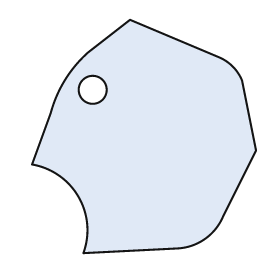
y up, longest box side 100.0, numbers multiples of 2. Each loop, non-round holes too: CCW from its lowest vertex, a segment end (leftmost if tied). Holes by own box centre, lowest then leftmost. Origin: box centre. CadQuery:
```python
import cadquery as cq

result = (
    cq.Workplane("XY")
    .moveTo(-26.0, -50.0)
    .lineTo(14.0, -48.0)
    .threePointArc((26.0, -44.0), (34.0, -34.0))
    .lineTo(48.0, -6.0)
    .lineTo(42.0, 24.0)
    .threePointArc((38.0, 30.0), (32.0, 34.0))
    .lineTo(-6.0, 50.0)
    .lineTo(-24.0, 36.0)
    .threePointArc((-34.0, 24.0), (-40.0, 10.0))
    .lineTo(-48.0, -12.0)
    .threePointArc((-28.0, -26.0), (-26.0, -50.0))
    .close()
    .moveTo(-22.0, 20.0)
    .circle(6.0)
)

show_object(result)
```